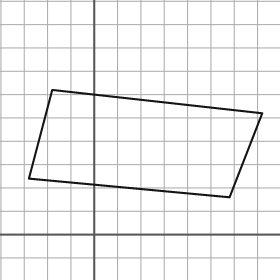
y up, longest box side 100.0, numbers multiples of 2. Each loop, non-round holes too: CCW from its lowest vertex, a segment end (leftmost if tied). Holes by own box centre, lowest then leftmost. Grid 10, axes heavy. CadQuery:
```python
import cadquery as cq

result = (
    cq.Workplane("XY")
    .moveTo(58.0, 16.0)
    .lineTo(72.0, 52.0)
    .lineTo(-18.0, 62.0)
    .lineTo(-28.0, 24.0)
    .close()
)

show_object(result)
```